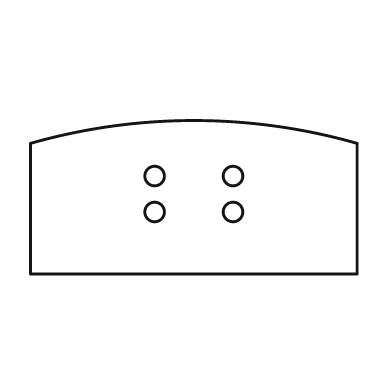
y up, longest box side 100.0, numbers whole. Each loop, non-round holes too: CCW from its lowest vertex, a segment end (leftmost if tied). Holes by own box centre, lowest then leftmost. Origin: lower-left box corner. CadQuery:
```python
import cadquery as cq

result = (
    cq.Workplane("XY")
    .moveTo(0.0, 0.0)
    .lineTo(100.0, 0.0)
    .lineTo(100.0, 40.0)
    .threePointArc((50.0, 47.0), (0.0, 40.0))
    .close()
    .moveTo(38.0, 19.0)
    .circle(3.0)
    .moveTo(62.0, 19.0)
    .circle(3.0)
    .moveTo(38.0, 30.0)
    .circle(3.0)
    .moveTo(62.0, 30.0)
    .circle(3.0)
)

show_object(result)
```